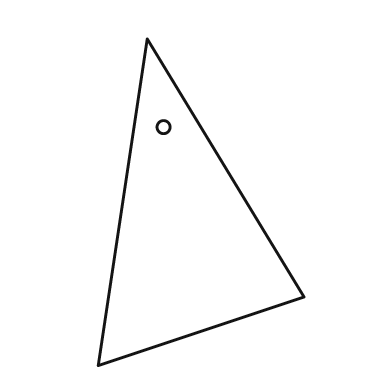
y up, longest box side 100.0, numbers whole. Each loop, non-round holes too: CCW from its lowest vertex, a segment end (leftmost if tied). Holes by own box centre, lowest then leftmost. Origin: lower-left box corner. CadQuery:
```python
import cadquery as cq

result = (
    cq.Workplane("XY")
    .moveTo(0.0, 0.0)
    .lineTo(63.0, 21.0)
    .lineTo(15.0, 100.0)
    .close()
    .moveTo(20.0, 73.0)
    .circle(2.0)
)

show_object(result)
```